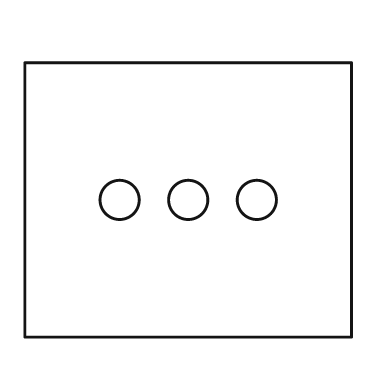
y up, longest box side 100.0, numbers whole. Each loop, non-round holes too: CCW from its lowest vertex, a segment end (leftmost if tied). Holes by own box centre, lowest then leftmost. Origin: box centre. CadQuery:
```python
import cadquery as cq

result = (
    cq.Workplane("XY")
    .moveTo(-50.0, -42.0)
    .lineTo(50.0, -42.0)
    .lineTo(50.0, 42.0)
    .lineTo(-50.0, 42.0)
    .close()
    .moveTo(-21.0, 0.0)
    .circle(6.0)
    .moveTo(0.0, 0.0)
    .circle(6.0)
    .moveTo(21.0, 0.0)
    .circle(6.0)
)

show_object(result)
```